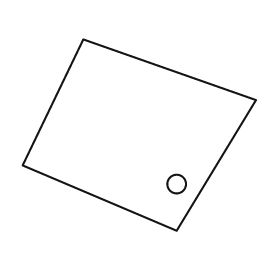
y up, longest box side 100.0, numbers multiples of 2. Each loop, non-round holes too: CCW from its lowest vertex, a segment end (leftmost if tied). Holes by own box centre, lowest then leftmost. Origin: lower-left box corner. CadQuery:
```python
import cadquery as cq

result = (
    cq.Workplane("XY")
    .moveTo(66.0, 0.0)
    .lineTo(100.0, 56.0)
    .lineTo(26.0, 82.0)
    .lineTo(0.0, 28.0)
    .close()
    .moveTo(66.0, 20.0)
    .circle(4.0)
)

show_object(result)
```